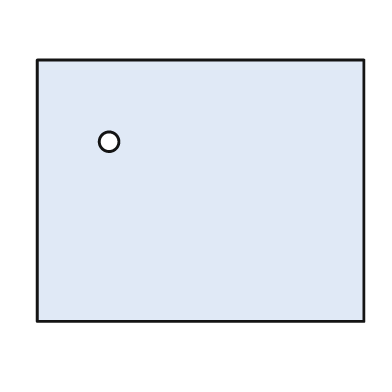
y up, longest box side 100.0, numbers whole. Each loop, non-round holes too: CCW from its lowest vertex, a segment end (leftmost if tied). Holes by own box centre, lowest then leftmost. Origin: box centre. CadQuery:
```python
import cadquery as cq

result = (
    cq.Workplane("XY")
    .moveTo(-50.0, -40.0)
    .lineTo(50.0, -40.0)
    .lineTo(50.0, 40.0)
    .lineTo(-50.0, 40.0)
    .close()
    .moveTo(-28.0, 15.0)
    .circle(3.0)
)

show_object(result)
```